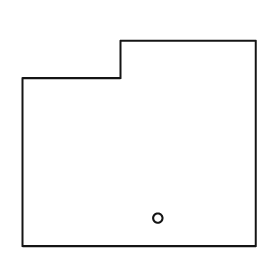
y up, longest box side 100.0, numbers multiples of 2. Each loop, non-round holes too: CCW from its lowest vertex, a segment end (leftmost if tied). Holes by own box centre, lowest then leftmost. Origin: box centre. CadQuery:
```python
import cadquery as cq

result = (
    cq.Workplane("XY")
    .moveTo(-50.0, -44.0)
    .lineTo(50.0, -44.0)
    .lineTo(50.0, 44.0)
    .lineTo(-8.0, 44.0)
    .lineTo(-8.0, 28.0)
    .lineTo(-50.0, 28.0)
    .close()
    .moveTo(8.0, -32.0)
    .circle(2.0)
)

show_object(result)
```